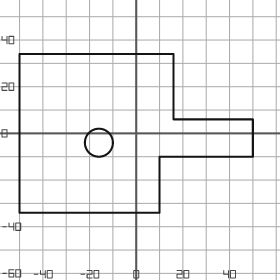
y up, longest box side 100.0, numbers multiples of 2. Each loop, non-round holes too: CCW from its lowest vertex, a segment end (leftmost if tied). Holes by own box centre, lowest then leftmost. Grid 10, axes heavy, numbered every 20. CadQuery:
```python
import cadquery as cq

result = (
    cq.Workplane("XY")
    .moveTo(-50.0, -34.0)
    .lineTo(10.0, -34.0)
    .lineTo(10.0, -10.0)
    .lineTo(50.0, -10.0)
    .lineTo(50.0, 6.0)
    .lineTo(16.0, 6.0)
    .lineTo(16.0, 34.0)
    .lineTo(-50.0, 34.0)
    .close()
    .moveTo(-16.0, -4.0)
    .circle(6.0)
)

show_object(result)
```